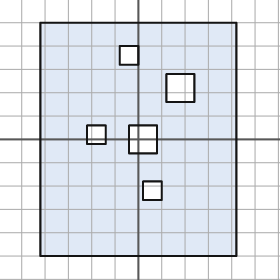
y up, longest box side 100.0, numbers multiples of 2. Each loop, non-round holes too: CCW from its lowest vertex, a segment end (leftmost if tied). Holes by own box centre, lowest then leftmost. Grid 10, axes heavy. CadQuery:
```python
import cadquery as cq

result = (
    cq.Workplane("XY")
    .moveTo(-42.0, -50.0)
    .lineTo(42.0, -50.0)
    .lineTo(42.0, 50.0)
    .lineTo(-42.0, 50.0)
    .close()
    .moveTo(2.0, -26.0)
    .lineTo(10.0, -26.0)
    .lineTo(10.0, -18.0)
    .lineTo(2.0, -18.0)
    .close()
    .moveTo(-4.0, -6.0)
    .lineTo(8.0, -6.0)
    .lineTo(8.0, 6.0)
    .lineTo(-4.0, 6.0)
    .close()
    .moveTo(-22.0, -2.0)
    .lineTo(-14.0, -2.0)
    .lineTo(-14.0, 6.0)
    .lineTo(-22.0, 6.0)
    .close()
    .moveTo(12.0, 16.0)
    .lineTo(24.0, 16.0)
    .lineTo(24.0, 28.0)
    .lineTo(12.0, 28.0)
    .close()
    .moveTo(-8.0, 32.0)
    .lineTo(0.0, 32.0)
    .lineTo(0.0, 40.0)
    .lineTo(-8.0, 40.0)
    .close()
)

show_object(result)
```